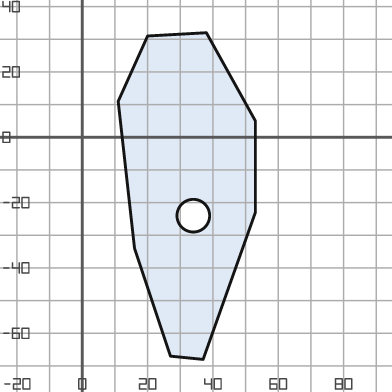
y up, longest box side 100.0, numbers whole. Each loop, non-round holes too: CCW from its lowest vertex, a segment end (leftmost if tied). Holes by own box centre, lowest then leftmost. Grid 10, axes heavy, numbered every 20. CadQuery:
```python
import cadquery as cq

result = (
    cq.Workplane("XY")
    .moveTo(37.0, -68.0)
    .lineTo(53.0, -23.0)
    .lineTo(53.0, 5.0)
    .lineTo(38.0, 32.0)
    .lineTo(20.0, 31.0)
    .lineTo(11.0, 11.0)
    .lineTo(16.0, -34.0)
    .lineTo(27.0, -67.0)
    .close()
    .moveTo(34.0, -24.0)
    .circle(5.0)
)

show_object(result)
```